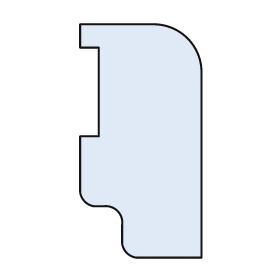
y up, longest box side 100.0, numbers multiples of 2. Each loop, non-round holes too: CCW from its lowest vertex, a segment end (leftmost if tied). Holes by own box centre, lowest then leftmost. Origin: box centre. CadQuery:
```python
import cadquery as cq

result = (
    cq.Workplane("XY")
    .moveTo(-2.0, -50.0)
    .lineTo(26.0, -50.0)
    .lineTo(26.0, 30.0)
    .threePointArc((20.0, 44.0), (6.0, 50.0))
    .lineTo(-26.0, 50.0)
    .lineTo(-26.0, 40.0)
    .lineTo(-18.0, 40.0)
    .lineTo(-18.0, 2.0)
    .lineTo(-26.0, 2.0)
    .lineTo(-26.0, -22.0)
    .threePointArc((-24.0, -26.0), (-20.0, -28.0))
    .lineTo(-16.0, -28.0)
    .threePointArc((-10.0, -30.0), (-8.0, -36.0))
    .lineTo(-8.0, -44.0)
    .threePointArc((-6.0, -48.0), (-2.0, -50.0))
    .close()
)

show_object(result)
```